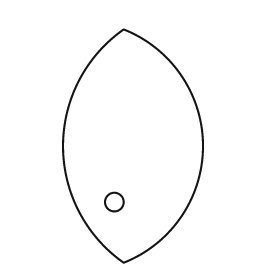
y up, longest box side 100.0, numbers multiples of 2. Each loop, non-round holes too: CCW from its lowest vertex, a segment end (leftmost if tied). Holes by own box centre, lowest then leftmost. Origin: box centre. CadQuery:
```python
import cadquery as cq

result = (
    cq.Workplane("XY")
    .moveTo(-4.0, -50.0)
    .threePointArc((30.0, 0.0), (-4.0, 50.0))
    .threePointArc((-30.0, 0.0), (-4.0, -50.0))
    .close()
    .moveTo(-8.0, -24.0)
    .circle(4.0)
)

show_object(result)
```